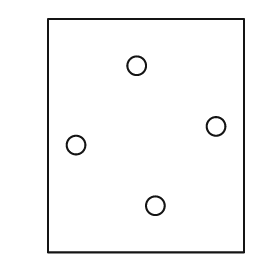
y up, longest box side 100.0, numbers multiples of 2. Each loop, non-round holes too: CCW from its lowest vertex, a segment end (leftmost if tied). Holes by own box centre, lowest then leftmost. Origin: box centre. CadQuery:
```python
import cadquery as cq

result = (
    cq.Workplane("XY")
    .moveTo(-42.0, -50.0)
    .lineTo(42.0, -50.0)
    .lineTo(42.0, 50.0)
    .lineTo(-42.0, 50.0)
    .close()
    .moveTo(4.0, -30.0)
    .circle(4.0)
    .moveTo(-30.0, -4.0)
    .circle(4.0)
    .moveTo(30.0, 4.0)
    .circle(4.0)
    .moveTo(-4.0, 30.0)
    .circle(4.0)
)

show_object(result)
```